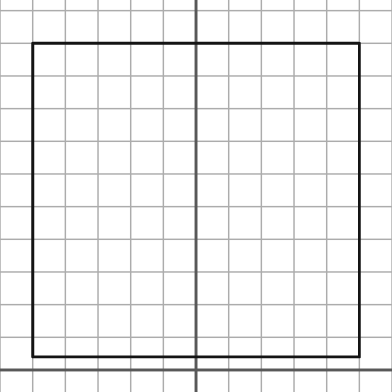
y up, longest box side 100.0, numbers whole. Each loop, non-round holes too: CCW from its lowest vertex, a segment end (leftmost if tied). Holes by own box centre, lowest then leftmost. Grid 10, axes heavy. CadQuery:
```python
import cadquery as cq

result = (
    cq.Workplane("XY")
    .moveTo(-50.0, 4.0)
    .lineTo(50.0, 4.0)
    .lineTo(50.0, 100.0)
    .lineTo(-50.0, 100.0)
    .close()
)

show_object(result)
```